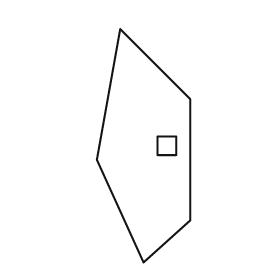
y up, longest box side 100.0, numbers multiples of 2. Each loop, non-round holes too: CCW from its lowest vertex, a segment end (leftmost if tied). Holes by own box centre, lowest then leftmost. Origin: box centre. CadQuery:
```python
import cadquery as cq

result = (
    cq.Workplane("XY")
    .moveTo(0.0, -50.0)
    .lineTo(20.0, -32.0)
    .lineTo(20.0, 20.0)
    .lineTo(-10.0, 50.0)
    .lineTo(-20.0, -6.0)
    .close()
    .moveTo(6.0, -4.0)
    .lineTo(14.0, -4.0)
    .lineTo(14.0, 4.0)
    .lineTo(6.0, 4.0)
    .close()
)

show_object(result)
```